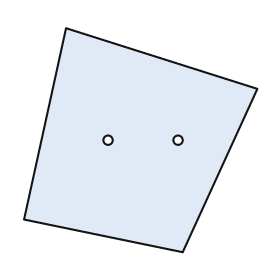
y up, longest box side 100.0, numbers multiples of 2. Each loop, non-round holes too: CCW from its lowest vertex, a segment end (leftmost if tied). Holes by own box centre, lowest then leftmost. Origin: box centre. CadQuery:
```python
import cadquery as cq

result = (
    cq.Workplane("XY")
    .moveTo(18.0, -48.0)
    .lineTo(50.0, 22.0)
    .lineTo(-32.0, 48.0)
    .lineTo(-50.0, -34.0)
    .close()
    .moveTo(-14.0, 0.0)
    .circle(2.0)
    .moveTo(16.0, 0.0)
    .circle(2.0)
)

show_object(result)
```